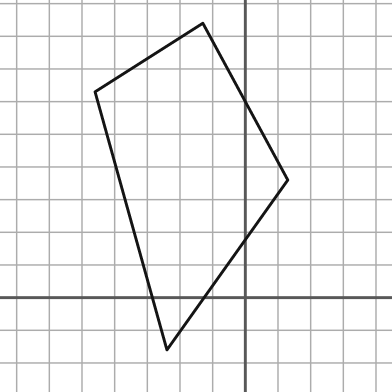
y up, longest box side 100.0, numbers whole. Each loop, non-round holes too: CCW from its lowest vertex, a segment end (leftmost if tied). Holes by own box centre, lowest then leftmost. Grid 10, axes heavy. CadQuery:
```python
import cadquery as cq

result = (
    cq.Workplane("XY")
    .moveTo(-24.0, -16.0)
    .lineTo(13.0, 36.0)
    .lineTo(-13.0, 84.0)
    .lineTo(-46.0, 63.0)
    .close()
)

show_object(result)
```